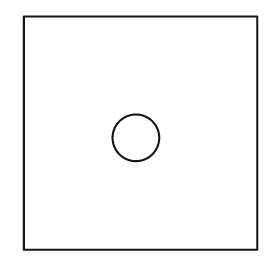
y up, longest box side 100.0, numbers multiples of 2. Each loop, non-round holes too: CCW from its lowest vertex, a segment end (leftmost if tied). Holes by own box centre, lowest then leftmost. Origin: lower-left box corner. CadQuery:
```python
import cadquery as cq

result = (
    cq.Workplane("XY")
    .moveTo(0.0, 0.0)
    .lineTo(100.0, 0.0)
    .lineTo(100.0, 100.0)
    .lineTo(0.0, 100.0)
    .close()
    .moveTo(48.0, 48.0)
    .circle(10.0)
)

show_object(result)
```